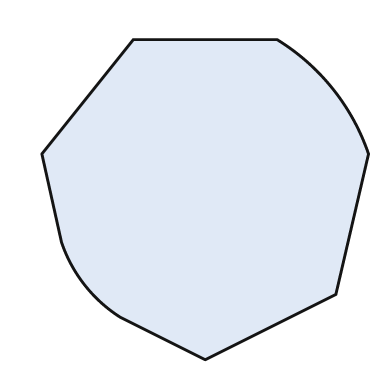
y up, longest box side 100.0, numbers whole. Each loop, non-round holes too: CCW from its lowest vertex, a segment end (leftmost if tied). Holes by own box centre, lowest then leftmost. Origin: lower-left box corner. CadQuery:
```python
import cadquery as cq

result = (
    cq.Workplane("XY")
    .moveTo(50.0, 0.0)
    .lineTo(90.0, 20.0)
    .lineTo(100.0, 63.0)
    .threePointArc((89.0, 83.0), (72.0, 98.0))
    .lineTo(28.0, 98.0)
    .lineTo(0.0, 63.0)
    .lineTo(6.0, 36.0)
    .threePointArc((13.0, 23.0), (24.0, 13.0))
    .close()
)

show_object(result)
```